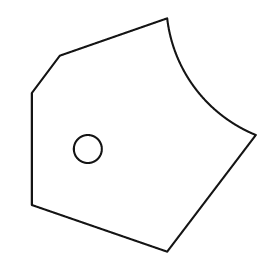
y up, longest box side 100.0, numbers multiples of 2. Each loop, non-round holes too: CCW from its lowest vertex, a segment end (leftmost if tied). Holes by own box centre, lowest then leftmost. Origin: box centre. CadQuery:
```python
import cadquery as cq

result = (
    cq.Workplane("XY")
    .moveTo(10.0, -50.0)
    .lineTo(48.0, 0.0)
    .threePointArc((22.0, 20.0), (10.0, 50.0))
    .lineTo(-36.0, 34.0)
    .lineTo(-48.0, 18.0)
    .lineTo(-48.0, -30.0)
    .close()
    .moveTo(-24.0, -6.0)
    .circle(6.0)
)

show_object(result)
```